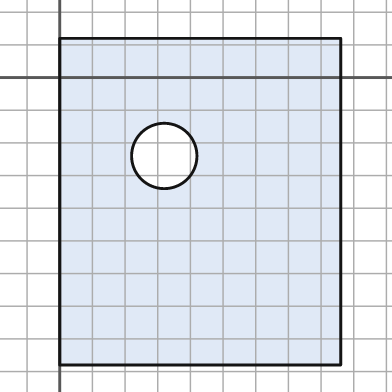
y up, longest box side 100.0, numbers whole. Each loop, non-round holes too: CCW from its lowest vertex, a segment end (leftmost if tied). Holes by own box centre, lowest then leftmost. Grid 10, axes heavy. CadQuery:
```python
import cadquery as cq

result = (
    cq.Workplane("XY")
    .moveTo(0.0, -88.0)
    .lineTo(86.0, -88.0)
    .lineTo(86.0, 12.0)
    .lineTo(0.0, 12.0)
    .close()
    .moveTo(32.0, -24.0)
    .circle(10.0)
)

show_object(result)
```